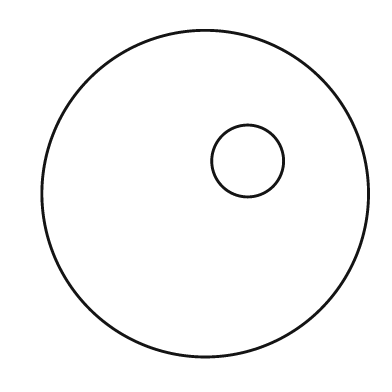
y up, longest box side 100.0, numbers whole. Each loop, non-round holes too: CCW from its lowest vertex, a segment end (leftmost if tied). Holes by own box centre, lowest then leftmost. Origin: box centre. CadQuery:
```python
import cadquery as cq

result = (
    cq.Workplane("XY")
    .moveTo(0.0, 0.0)
    .circle(50.0)
    .moveTo(13.0, 10.0)
    .circle(11.0)
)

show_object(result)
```